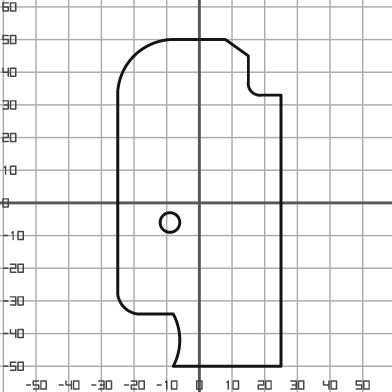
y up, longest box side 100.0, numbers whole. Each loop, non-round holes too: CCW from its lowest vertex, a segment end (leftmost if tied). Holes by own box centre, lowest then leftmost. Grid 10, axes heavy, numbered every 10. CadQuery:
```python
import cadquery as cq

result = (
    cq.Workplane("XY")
    .moveTo(-8.0, -50.0)
    .lineTo(25.0, -50.0)
    .lineTo(25.0, 33.0)
    .lineTo(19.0, 33.0)
    .threePointArc((16.0, 34.0), (15.0, 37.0))
    .lineTo(15.0, 45.0)
    .lineTo(8.0, 50.0)
    .lineTo(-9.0, 50.0)
    .threePointArc((-20.0, 45.0), (-25.0, 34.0))
    .lineTo(-25.0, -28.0)
    .threePointArc((-23.0, -32.0), (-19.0, -34.0))
    .lineTo(-8.0, -34.0)
    .threePointArc((-6.0, -42.0), (-8.0, -50.0))
    .close()
    .moveTo(-9.0, -6.0)
    .circle(3.0)
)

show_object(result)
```